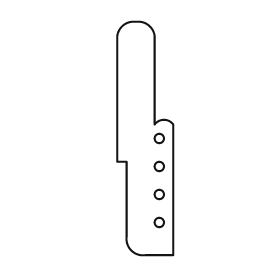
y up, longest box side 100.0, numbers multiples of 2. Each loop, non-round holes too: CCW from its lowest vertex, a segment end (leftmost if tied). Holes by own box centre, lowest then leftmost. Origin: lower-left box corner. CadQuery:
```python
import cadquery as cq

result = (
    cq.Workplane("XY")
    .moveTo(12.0, 0.0)
    .lineTo(24.0, 0.0)
    .lineTo(24.0, 56.0)
    .threePointArc((20.0, 58.0), (16.0, 56.0))
    .lineTo(16.0, 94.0)
    .threePointArc((14.0, 98.0), (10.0, 100.0))
    .lineTo(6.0, 100.0)
    .threePointArc((2.0, 98.0), (0.0, 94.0))
    .lineTo(0.0, 40.0)
    .lineTo(4.0, 40.0)
    .lineTo(4.0, 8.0)
    .threePointArc((6.0, 2.0), (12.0, 0.0))
    .close()
    .moveTo(18.0, 14.0)
    .circle(2.0)
    .moveTo(18.0, 26.0)
    .circle(2.0)
    .moveTo(18.0, 38.0)
    .circle(2.0)
    .moveTo(18.0, 50.0)
    .circle(2.0)
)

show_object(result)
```